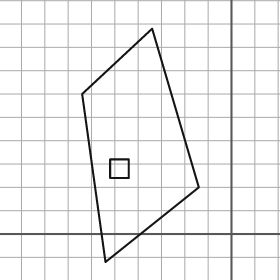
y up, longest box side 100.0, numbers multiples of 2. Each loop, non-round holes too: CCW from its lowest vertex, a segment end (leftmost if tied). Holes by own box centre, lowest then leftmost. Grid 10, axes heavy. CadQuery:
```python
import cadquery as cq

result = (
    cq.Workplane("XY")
    .moveTo(-54.0, -12.0)
    .lineTo(-14.0, 20.0)
    .lineTo(-34.0, 88.0)
    .lineTo(-64.0, 60.0)
    .close()
    .moveTo(-52.0, 24.0)
    .lineTo(-44.0, 24.0)
    .lineTo(-44.0, 32.0)
    .lineTo(-52.0, 32.0)
    .close()
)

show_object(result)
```